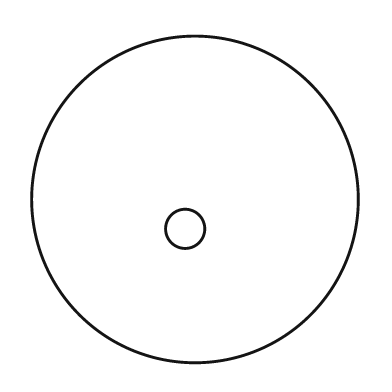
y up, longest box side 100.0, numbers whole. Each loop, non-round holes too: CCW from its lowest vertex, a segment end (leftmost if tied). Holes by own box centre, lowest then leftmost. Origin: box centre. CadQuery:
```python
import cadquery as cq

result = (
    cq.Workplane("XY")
    .moveTo(0.0, 0.0)
    .circle(50.0)
    .moveTo(-3.0, -9.0)
    .circle(6.0)
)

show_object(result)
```